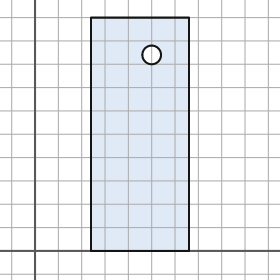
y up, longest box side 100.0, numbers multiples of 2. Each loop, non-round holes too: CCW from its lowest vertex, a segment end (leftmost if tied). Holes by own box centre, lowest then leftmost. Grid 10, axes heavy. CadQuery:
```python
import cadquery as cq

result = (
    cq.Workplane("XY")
    .moveTo(24.0, 0.0)
    .lineTo(66.0, 0.0)
    .lineTo(66.0, 100.0)
    .lineTo(24.0, 100.0)
    .close()
    .moveTo(50.0, 84.0)
    .circle(4.0)
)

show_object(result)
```